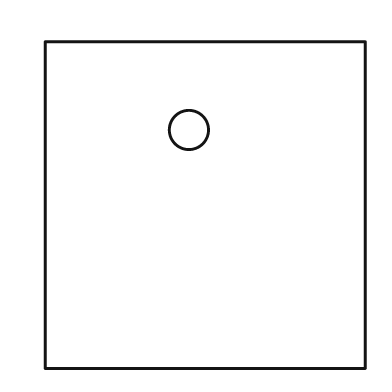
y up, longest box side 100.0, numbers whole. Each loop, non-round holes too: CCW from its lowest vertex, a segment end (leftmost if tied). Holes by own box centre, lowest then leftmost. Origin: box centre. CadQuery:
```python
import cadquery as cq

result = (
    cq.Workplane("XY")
    .moveTo(-49.0, -50.0)
    .lineTo(49.0, -50.0)
    .lineTo(49.0, 50.0)
    .lineTo(-49.0, 50.0)
    .close()
    .moveTo(-5.0, 23.0)
    .circle(6.0)
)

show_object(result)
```